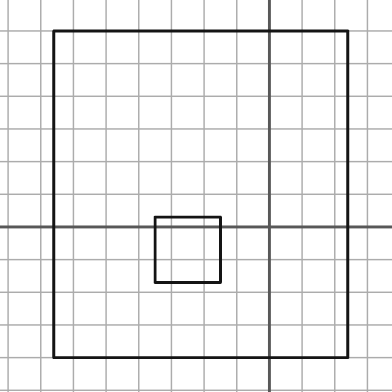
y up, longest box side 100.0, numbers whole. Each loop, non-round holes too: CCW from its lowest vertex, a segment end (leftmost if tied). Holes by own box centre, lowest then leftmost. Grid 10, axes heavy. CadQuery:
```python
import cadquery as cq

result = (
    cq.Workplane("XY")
    .moveTo(-66.0, -40.0)
    .lineTo(24.0, -40.0)
    .lineTo(24.0, 60.0)
    .lineTo(-66.0, 60.0)
    .close()
    .moveTo(-35.0, -17.0)
    .lineTo(-15.0, -17.0)
    .lineTo(-15.0, 3.0)
    .lineTo(-35.0, 3.0)
    .close()
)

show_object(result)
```